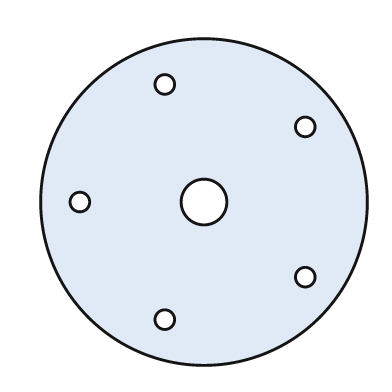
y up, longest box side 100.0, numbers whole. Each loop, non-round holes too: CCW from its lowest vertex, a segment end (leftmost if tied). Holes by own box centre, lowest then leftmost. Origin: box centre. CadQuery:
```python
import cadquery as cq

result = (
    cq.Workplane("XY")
    .moveTo(0.0, 0.0)
    .circle(50.0)
    .moveTo(-12.0, -36.0)
    .circle(3.0)
    .moveTo(31.0, -23.0)
    .circle(3.0)
    .moveTo(-38.0, 0.0)
    .circle(3.0)
    .moveTo(0.0, 0.0)
    .circle(7.0)
    .moveTo(31.0, 23.0)
    .circle(3.0)
    .moveTo(-12.0, 36.0)
    .circle(3.0)
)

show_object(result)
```